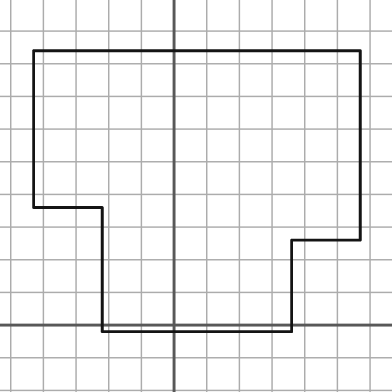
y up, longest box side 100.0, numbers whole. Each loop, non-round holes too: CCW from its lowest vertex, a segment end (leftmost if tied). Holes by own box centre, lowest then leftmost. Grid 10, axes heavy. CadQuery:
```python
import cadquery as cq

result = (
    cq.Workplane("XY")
    .moveTo(-22.0, -2.0)
    .lineTo(36.0, -2.0)
    .lineTo(36.0, 26.0)
    .lineTo(57.0, 26.0)
    .lineTo(57.0, 84.0)
    .lineTo(-43.0, 84.0)
    .lineTo(-43.0, 36.0)
    .lineTo(-22.0, 36.0)
    .close()
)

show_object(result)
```